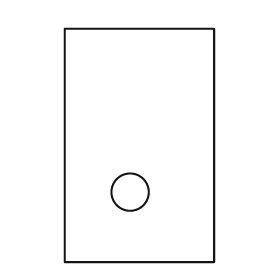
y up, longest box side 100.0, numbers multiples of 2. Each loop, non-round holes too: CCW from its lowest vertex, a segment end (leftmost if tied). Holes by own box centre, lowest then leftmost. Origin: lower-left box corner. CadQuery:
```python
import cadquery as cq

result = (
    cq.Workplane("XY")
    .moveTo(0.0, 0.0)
    .lineTo(64.0, 0.0)
    .lineTo(64.0, 100.0)
    .lineTo(0.0, 100.0)
    .close()
    .moveTo(28.0, 30.0)
    .circle(8.0)
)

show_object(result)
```